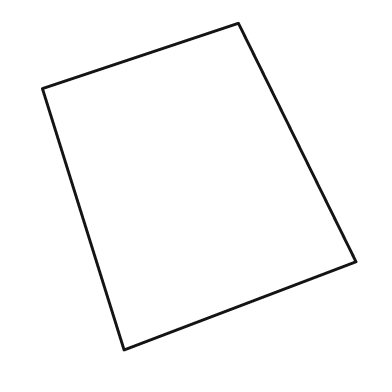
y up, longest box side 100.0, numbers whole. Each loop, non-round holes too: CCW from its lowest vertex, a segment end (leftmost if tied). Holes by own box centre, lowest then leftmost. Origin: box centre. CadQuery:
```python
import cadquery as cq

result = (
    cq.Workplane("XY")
    .moveTo(-23.0, -50.0)
    .lineTo(48.0, -23.0)
    .lineTo(12.0, 50.0)
    .lineTo(-48.0, 30.0)
    .close()
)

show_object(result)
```